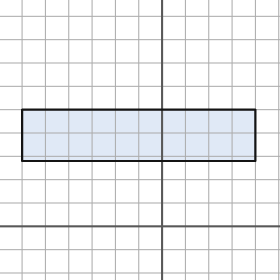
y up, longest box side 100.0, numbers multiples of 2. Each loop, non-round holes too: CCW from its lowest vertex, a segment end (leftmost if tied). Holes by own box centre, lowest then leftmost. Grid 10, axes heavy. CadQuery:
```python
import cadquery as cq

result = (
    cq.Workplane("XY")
    .moveTo(-60.0, 28.0)
    .lineTo(40.0, 28.0)
    .lineTo(40.0, 50.0)
    .lineTo(-60.0, 50.0)
    .close()
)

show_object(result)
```